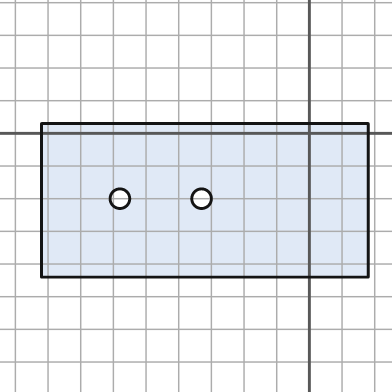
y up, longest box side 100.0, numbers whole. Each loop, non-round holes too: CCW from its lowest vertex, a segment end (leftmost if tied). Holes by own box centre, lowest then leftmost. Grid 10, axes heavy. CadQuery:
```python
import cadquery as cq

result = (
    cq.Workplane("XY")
    .moveTo(-82.0, -44.0)
    .lineTo(18.0, -44.0)
    .lineTo(18.0, 3.0)
    .lineTo(-82.0, 3.0)
    .close()
    .moveTo(-58.0, -20.0)
    .circle(3.0)
    .moveTo(-33.0, -20.0)
    .circle(3.0)
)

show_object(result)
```